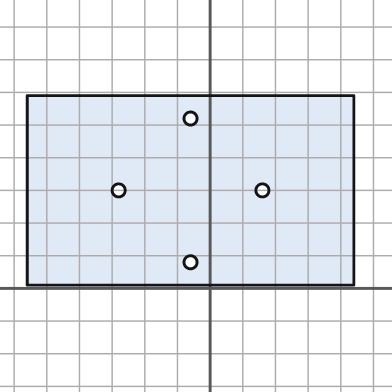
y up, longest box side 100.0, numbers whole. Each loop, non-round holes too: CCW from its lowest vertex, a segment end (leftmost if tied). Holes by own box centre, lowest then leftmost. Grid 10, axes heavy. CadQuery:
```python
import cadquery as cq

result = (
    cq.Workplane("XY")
    .moveTo(-56.0, 1.0)
    .lineTo(44.0, 1.0)
    .lineTo(44.0, 59.0)
    .lineTo(-56.0, 59.0)
    .close()
    .moveTo(-6.0, 8.0)
    .circle(2.0)
    .moveTo(-28.0, 30.0)
    .circle(2.0)
    .moveTo(16.0, 30.0)
    .circle(2.0)
    .moveTo(-6.0, 52.0)
    .circle(2.0)
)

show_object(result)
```